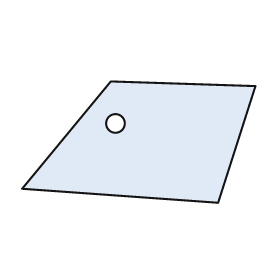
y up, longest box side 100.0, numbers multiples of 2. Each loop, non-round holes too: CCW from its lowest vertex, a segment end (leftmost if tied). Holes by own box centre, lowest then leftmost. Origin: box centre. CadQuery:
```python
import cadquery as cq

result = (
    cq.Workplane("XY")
    .moveTo(34.0, -26.0)
    .lineTo(50.0, 24.0)
    .lineTo(-12.0, 26.0)
    .lineTo(-50.0, -20.0)
    .close()
    .moveTo(-10.0, 8.0)
    .circle(4.0)
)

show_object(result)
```